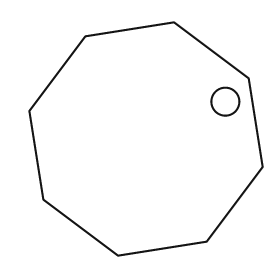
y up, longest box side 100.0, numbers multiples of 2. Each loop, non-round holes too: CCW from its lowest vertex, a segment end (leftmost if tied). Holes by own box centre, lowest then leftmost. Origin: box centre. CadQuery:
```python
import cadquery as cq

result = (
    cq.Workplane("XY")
    .moveTo(-12.0, -50.0)
    .lineTo(26.0, -44.0)
    .lineTo(50.0, -12.0)
    .lineTo(44.0, 26.0)
    .lineTo(12.0, 50.0)
    .lineTo(-26.0, 44.0)
    .lineTo(-50.0, 12.0)
    .lineTo(-44.0, -26.0)
    .close()
    .moveTo(34.0, 16.0)
    .circle(6.0)
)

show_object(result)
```